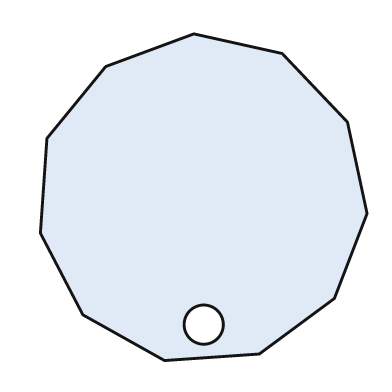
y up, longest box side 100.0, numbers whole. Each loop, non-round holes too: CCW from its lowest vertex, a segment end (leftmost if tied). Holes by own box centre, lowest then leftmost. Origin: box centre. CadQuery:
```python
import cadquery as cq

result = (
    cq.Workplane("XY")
    .moveTo(-12.0, -50.0)
    .lineTo(17.0, -48.0)
    .lineTo(40.0, -31.0)
    .lineTo(50.0, -5.0)
    .lineTo(44.0, 23.0)
    .lineTo(24.0, 44.0)
    .lineTo(-3.0, 50.0)
    .lineTo(-30.0, 40.0)
    .lineTo(-48.0, 18.0)
    .lineTo(-50.0, -11.0)
    .lineTo(-37.0, -36.0)
    .close()
    .moveTo(0.0, -39.0)
    .circle(6.0)
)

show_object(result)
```